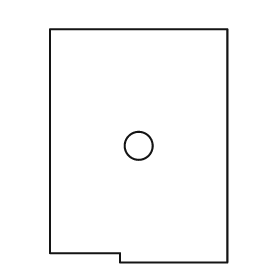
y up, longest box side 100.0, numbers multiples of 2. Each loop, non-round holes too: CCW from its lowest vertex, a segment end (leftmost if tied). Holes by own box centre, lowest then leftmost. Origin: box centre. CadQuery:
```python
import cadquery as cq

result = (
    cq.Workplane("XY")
    .moveTo(-8.0, -50.0)
    .lineTo(38.0, -50.0)
    .lineTo(38.0, 50.0)
    .lineTo(-38.0, 50.0)
    .lineTo(-38.0, -46.0)
    .lineTo(-8.0, -46.0)
    .close()
    .moveTo(0.0, 0.0)
    .circle(6.0)
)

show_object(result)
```